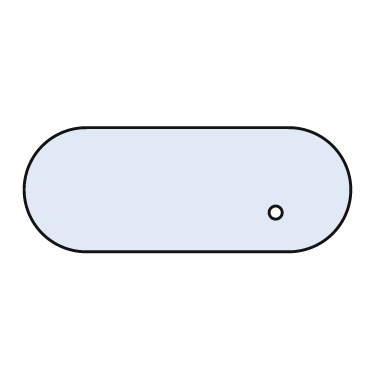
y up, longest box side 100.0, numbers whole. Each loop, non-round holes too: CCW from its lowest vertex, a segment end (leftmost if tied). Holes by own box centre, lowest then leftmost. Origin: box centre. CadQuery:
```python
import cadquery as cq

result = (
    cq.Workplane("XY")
    .moveTo(-31.0, -19.0)
    .lineTo(31.0, -19.0)
    .threePointArc((50.0, 0.0), (31.0, 19.0))
    .lineTo(-31.0, 19.0)
    .threePointArc((-50.0, 0.0), (-31.0, -19.0))
    .close()
    .moveTo(27.0, -7.0)
    .circle(2.0)
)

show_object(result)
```